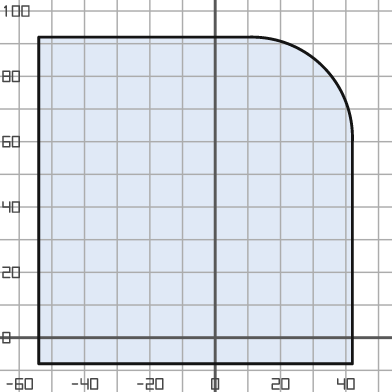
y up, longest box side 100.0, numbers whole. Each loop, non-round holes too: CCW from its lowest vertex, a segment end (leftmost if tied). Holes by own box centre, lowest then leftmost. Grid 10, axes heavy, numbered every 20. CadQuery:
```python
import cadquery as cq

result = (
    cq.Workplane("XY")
    .moveTo(-54.0, -8.0)
    .lineTo(42.0, -8.0)
    .lineTo(42.0, 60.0)
    .threePointArc((33.0, 83.0), (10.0, 92.0))
    .lineTo(-54.0, 92.0)
    .close()
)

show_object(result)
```